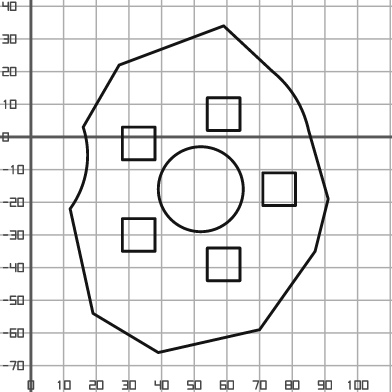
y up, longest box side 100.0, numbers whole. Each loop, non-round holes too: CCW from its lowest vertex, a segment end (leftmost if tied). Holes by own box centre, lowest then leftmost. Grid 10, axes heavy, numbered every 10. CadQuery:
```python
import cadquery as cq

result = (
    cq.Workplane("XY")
    .moveTo(39.0, -66.0)
    .lineTo(70.0, -59.0)
    .lineTo(87.0, -35.0)
    .lineTo(91.0, -19.0)
    .lineTo(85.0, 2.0)
    .threePointArc((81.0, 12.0), (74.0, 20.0))
    .lineTo(59.0, 34.0)
    .lineTo(27.0, 22.0)
    .lineTo(16.0, 3.0)
    .threePointArc((17.0, -10.0), (12.0, -22.0))
    .lineTo(19.0, -54.0)
    .close()
    .moveTo(54.0, -44.0)
    .lineTo(64.0, -44.0)
    .lineTo(64.0, -34.0)
    .lineTo(54.0, -34.0)
    .close()
    .moveTo(28.0, -35.0)
    .lineTo(38.0, -35.0)
    .lineTo(38.0, -25.0)
    .lineTo(28.0, -25.0)
    .close()
    .moveTo(52.0, -16.0)
    .circle(13.0)
    .moveTo(71.0, -21.0)
    .lineTo(81.0, -21.0)
    .lineTo(81.0, -11.0)
    .lineTo(71.0, -11.0)
    .close()
    .moveTo(28.0, -7.0)
    .lineTo(38.0, -7.0)
    .lineTo(38.0, 3.0)
    .lineTo(28.0, 3.0)
    .close()
    .moveTo(54.0, 2.0)
    .lineTo(64.0, 2.0)
    .lineTo(64.0, 12.0)
    .lineTo(54.0, 12.0)
    .close()
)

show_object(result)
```